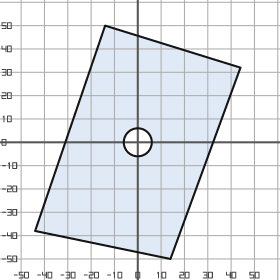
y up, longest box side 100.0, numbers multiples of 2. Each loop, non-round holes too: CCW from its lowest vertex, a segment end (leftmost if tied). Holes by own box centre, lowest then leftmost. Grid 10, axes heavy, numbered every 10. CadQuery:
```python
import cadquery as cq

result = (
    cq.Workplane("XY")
    .moveTo(14.0, -50.0)
    .lineTo(44.0, 32.0)
    .lineTo(-14.0, 50.0)
    .lineTo(-44.0, -38.0)
    .close()
    .moveTo(0.0, 0.0)
    .circle(6.0)
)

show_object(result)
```